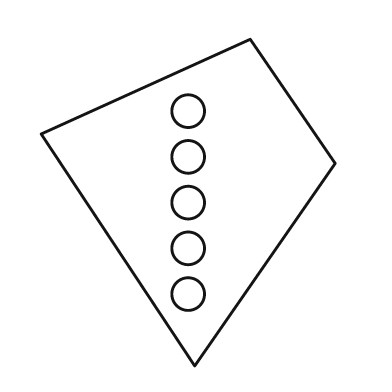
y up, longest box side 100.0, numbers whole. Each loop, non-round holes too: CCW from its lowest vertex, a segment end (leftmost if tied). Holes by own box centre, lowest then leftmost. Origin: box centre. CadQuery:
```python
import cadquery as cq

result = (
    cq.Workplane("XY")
    .moveTo(2.0, -50.0)
    .lineTo(45.0, 12.0)
    .lineTo(19.0, 50.0)
    .lineTo(-45.0, 21.0)
    .close()
    .moveTo(0.0, -28.0)
    .circle(5.0)
    .moveTo(0.0, -14.0)
    .circle(5.0)
    .moveTo(0.0, 0.0)
    .circle(5.0)
    .moveTo(0.0, 14.0)
    .circle(5.0)
    .moveTo(0.0, 28.0)
    .circle(5.0)
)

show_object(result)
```